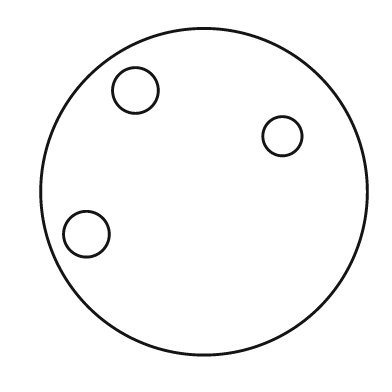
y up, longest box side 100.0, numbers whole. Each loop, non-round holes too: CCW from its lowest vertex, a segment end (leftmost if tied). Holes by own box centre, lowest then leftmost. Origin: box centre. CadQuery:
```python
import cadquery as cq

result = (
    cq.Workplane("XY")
    .moveTo(0.0, 0.0)
    .circle(50.0)
    .moveTo(-36.0, -13.0)
    .circle(7.0)
    .moveTo(24.0, 17.0)
    .circle(6.0)
    .moveTo(-21.0, 31.0)
    .circle(7.0)
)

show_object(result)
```